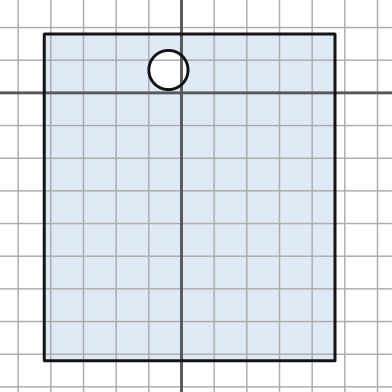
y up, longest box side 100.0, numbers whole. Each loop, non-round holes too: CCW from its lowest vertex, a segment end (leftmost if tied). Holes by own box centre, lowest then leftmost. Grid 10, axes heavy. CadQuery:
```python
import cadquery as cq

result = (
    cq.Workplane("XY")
    .moveTo(-42.0, -82.0)
    .lineTo(47.0, -82.0)
    .lineTo(47.0, 18.0)
    .lineTo(-42.0, 18.0)
    .close()
    .moveTo(-4.0, 7.0)
    .circle(6.0)
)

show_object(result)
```